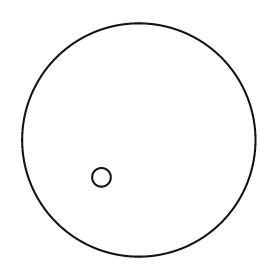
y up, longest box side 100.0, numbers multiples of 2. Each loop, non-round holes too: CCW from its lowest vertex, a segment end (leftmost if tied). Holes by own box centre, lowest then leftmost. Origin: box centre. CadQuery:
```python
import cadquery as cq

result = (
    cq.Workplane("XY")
    .moveTo(0.0, 0.0)
    .circle(50.0)
    .moveTo(-16.0, -16.0)
    .circle(4.0)
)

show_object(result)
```